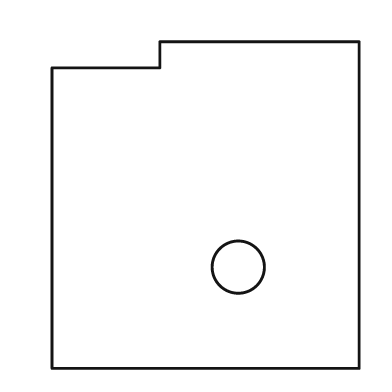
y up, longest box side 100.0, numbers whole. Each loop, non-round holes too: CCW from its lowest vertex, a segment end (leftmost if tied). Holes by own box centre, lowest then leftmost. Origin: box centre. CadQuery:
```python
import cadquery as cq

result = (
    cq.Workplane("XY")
    .moveTo(-47.0, -50.0)
    .lineTo(47.0, -50.0)
    .lineTo(47.0, 50.0)
    .lineTo(-14.0, 50.0)
    .lineTo(-14.0, 42.0)
    .lineTo(-47.0, 42.0)
    .close()
    .moveTo(10.0, -19.0)
    .circle(8.0)
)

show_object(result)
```